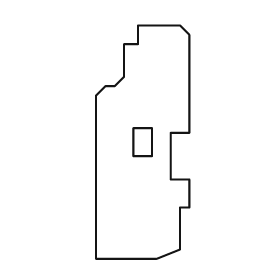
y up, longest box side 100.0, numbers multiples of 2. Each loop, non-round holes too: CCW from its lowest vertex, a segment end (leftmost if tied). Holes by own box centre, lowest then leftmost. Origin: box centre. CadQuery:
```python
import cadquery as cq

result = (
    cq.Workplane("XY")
    .moveTo(-20.0, -50.0)
    .lineTo(6.0, -50.0)
    .lineTo(16.0, -46.0)
    .lineTo(16.0, -28.0)
    .lineTo(20.0, -28.0)
    .lineTo(20.0, -16.0)
    .lineTo(12.0, -16.0)
    .lineTo(12.0, 4.0)
    .lineTo(20.0, 4.0)
    .lineTo(20.0, 46.0)
    .lineTo(16.0, 50.0)
    .lineTo(-2.0, 50.0)
    .lineTo(-2.0, 42.0)
    .lineTo(-8.0, 42.0)
    .lineTo(-8.0, 28.0)
    .lineTo(-12.0, 24.0)
    .lineTo(-16.0, 24.0)
    .lineTo(-20.0, 20.0)
    .close()
    .moveTo(-4.0, -6.0)
    .lineTo(4.0, -6.0)
    .lineTo(4.0, 6.0)
    .lineTo(-4.0, 6.0)
    .close()
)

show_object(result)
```